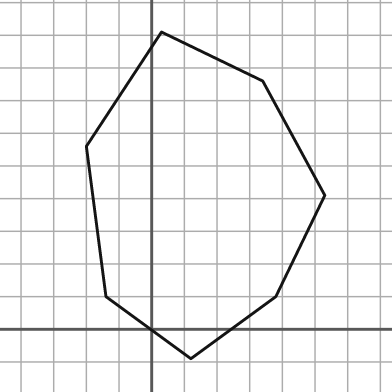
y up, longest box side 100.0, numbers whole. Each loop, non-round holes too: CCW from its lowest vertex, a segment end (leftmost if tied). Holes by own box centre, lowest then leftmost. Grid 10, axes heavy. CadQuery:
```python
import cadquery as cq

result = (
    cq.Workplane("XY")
    .moveTo(12.0, -9.0)
    .lineTo(38.0, 10.0)
    .lineTo(53.0, 41.0)
    .lineTo(34.0, 76.0)
    .lineTo(3.0, 91.0)
    .lineTo(-20.0, 56.0)
    .lineTo(-14.0, 10.0)
    .close()
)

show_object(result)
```